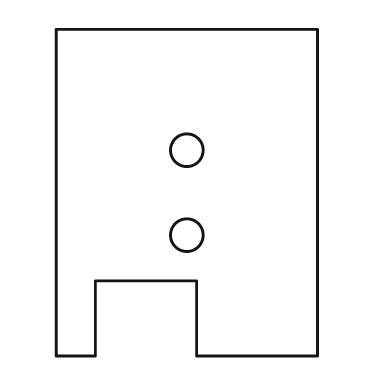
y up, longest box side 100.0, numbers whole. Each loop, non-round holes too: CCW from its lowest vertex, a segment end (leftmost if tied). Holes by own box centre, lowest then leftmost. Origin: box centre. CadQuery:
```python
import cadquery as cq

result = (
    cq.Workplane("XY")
    .moveTo(-40.0, -50.0)
    .lineTo(-28.0, -50.0)
    .lineTo(-28.0, -27.0)
    .lineTo(3.0, -27.0)
    .lineTo(3.0, -50.0)
    .lineTo(40.0, -50.0)
    .lineTo(40.0, 50.0)
    .lineTo(-40.0, 50.0)
    .close()
    .moveTo(0.0, -13.0)
    .circle(5.0)
    .moveTo(0.0, 13.0)
    .circle(5.0)
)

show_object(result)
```